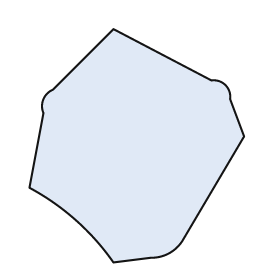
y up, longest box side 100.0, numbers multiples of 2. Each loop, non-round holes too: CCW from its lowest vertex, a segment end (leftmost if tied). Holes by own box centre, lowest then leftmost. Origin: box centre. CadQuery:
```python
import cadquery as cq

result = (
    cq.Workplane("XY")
    .moveTo(-10.0, -50.0)
    .lineTo(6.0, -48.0)
    .threePointArc((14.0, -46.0), (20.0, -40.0))
    .lineTo(46.0, 4.0)
    .lineTo(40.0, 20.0)
    .threePointArc((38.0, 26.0), (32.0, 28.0))
    .lineTo(-10.0, 50.0)
    .lineTo(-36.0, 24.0)
    .threePointArc((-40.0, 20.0), (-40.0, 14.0))
    .lineTo(-46.0, -18.0)
    .threePointArc((-26.0, -32.0), (-10.0, -50.0))
    .close()
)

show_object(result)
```